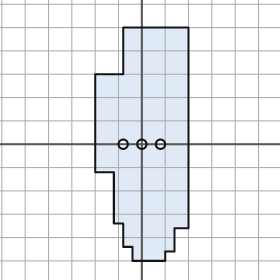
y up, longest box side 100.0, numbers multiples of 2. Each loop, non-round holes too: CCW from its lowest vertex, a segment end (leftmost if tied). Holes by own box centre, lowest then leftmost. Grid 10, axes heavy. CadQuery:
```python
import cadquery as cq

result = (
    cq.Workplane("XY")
    .moveTo(-4.0, -50.0)
    .lineTo(10.0, -50.0)
    .lineTo(10.0, -46.0)
    .lineTo(14.0, -46.0)
    .lineTo(14.0, -36.0)
    .lineTo(20.0, -36.0)
    .lineTo(20.0, 50.0)
    .lineTo(-8.0, 50.0)
    .lineTo(-8.0, 30.0)
    .lineTo(-20.0, 30.0)
    .lineTo(-20.0, -12.0)
    .lineTo(-12.0, -12.0)
    .lineTo(-12.0, -34.0)
    .lineTo(-8.0, -34.0)
    .lineTo(-8.0, -44.0)
    .lineTo(-4.0, -44.0)
    .close()
    .moveTo(-8.0, 0.0)
    .circle(2.0)
    .moveTo(0.0, 0.0)
    .circle(2.0)
    .moveTo(8.0, 0.0)
    .circle(2.0)
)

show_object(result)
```